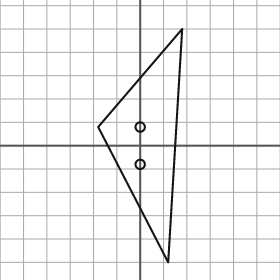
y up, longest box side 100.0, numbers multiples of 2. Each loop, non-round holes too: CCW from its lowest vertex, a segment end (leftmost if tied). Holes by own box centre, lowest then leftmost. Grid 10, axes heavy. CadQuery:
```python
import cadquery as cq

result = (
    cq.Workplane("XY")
    .moveTo(12.0, -50.0)
    .lineTo(18.0, 50.0)
    .lineTo(-18.0, 8.0)
    .close()
    .moveTo(0.0, -8.0)
    .circle(2.0)
    .moveTo(0.0, 8.0)
    .circle(2.0)
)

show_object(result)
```